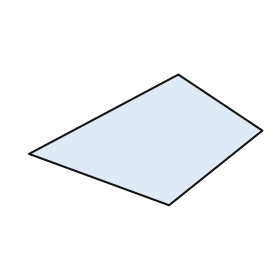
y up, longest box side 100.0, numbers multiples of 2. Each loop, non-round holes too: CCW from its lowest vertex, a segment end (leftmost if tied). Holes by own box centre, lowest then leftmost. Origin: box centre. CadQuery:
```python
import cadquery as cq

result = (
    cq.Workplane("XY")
    .moveTo(10.0, -28.0)
    .lineTo(50.0, 4.0)
    .lineTo(14.0, 28.0)
    .lineTo(-50.0, -6.0)
    .close()
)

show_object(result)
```